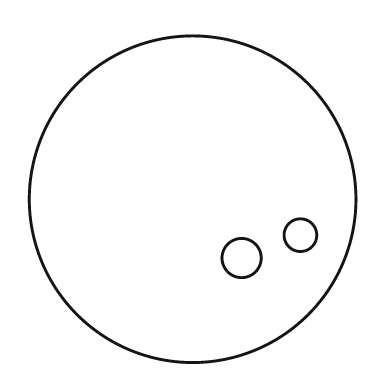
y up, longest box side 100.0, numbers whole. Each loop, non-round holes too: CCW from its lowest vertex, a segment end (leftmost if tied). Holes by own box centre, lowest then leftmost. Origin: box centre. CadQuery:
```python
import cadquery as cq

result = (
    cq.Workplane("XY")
    .moveTo(0.0, 0.0)
    .circle(50.0)
    .moveTo(15.0, -18.0)
    .circle(6.0)
    .moveTo(33.0, -11.0)
    .circle(5.0)
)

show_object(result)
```